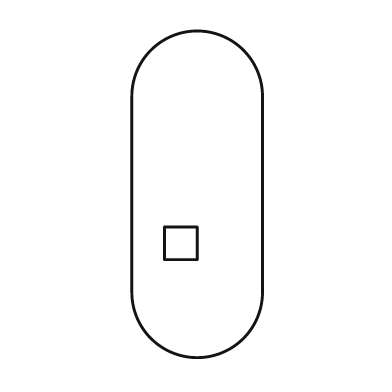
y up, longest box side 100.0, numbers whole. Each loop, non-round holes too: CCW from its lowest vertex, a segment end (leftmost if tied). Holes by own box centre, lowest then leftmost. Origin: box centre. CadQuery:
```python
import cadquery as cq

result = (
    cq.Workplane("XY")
    .moveTo(-20.0, -30.0)
    .threePointArc((0.0, -50.0), (20.0, -30.0))
    .lineTo(20.0, 30.0)
    .threePointArc((0.0, 50.0), (-20.0, 30.0))
    .close()
    .moveTo(-10.0, -20.0)
    .lineTo(0.0, -20.0)
    .lineTo(0.0, -10.0)
    .lineTo(-10.0, -10.0)
    .close()
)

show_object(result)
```